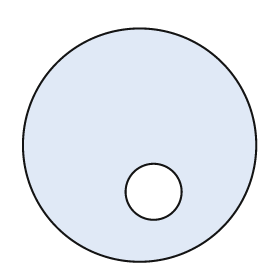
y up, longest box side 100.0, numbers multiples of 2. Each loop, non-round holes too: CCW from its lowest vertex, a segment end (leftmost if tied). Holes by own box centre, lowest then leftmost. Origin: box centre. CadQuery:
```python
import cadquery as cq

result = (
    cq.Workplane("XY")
    .moveTo(0.0, 0.0)
    .circle(50.0)
    .moveTo(6.0, -20.0)
    .circle(12.0)
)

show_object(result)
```